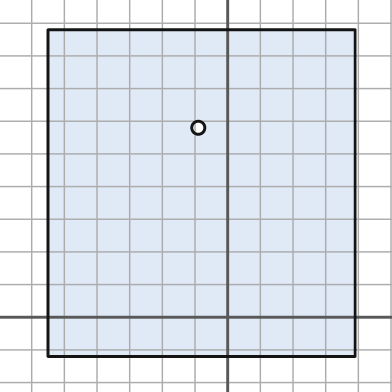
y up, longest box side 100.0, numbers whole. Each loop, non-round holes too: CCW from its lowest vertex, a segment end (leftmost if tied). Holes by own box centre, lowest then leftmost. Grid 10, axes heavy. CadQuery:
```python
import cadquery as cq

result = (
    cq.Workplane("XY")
    .moveTo(-55.0, -12.0)
    .lineTo(39.0, -12.0)
    .lineTo(39.0, 88.0)
    .lineTo(-55.0, 88.0)
    .close()
    .moveTo(-9.0, 58.0)
    .circle(2.0)
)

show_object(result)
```